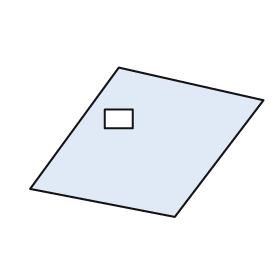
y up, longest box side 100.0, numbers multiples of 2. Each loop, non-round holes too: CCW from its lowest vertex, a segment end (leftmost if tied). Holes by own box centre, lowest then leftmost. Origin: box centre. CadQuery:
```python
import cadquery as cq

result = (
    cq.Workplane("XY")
    .moveTo(12.0, -32.0)
    .lineTo(50.0, 18.0)
    .lineTo(-12.0, 32.0)
    .lineTo(-50.0, -20.0)
    .close()
    .moveTo(-18.0, 6.0)
    .lineTo(-6.0, 6.0)
    .lineTo(-6.0, 14.0)
    .lineTo(-18.0, 14.0)
    .close()
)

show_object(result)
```